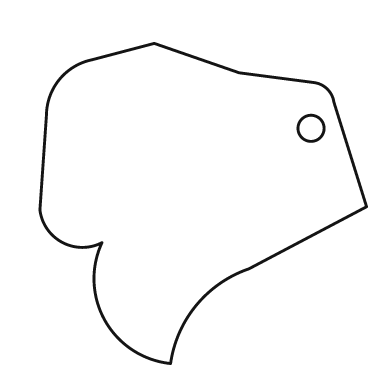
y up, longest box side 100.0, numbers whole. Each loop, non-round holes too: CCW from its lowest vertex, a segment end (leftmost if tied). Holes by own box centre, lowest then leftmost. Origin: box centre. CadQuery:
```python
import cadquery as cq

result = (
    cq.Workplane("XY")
    .moveTo(-10.0, -49.0)
    .threePointArc((-2.0, -31.0), (14.0, -20.0))
    .lineTo(50.0, -1.0)
    .lineTo(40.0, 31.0)
    .threePointArc((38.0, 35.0), (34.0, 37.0))
    .lineTo(11.0, 40.0)
    .lineTo(-15.0, 49.0)
    .lineTo(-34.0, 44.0)
    .threePointArc((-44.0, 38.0), (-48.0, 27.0))
    .lineTo(-50.0, -2.0)
    .threePointArc((-43.0, -12.0), (-31.0, -12.0))
    .threePointArc((-30.0, -36.0), (-10.0, -49.0))
    .close()
    .moveTo(33.0, 23.0)
    .circle(4.0)
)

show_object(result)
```